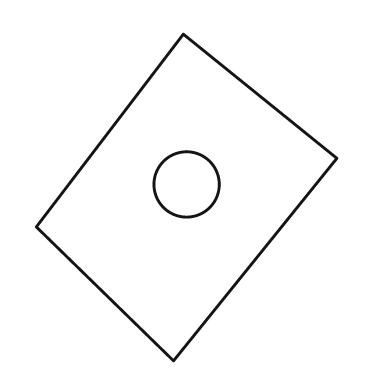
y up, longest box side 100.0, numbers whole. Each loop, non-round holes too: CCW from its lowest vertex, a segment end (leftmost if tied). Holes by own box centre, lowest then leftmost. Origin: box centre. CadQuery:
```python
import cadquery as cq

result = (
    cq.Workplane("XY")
    .moveTo(-4.0, -50.0)
    .lineTo(46.0, 12.0)
    .lineTo(-1.0, 50.0)
    .lineTo(-46.0, -9.0)
    .close()
    .moveTo(0.0, 4.0)
    .circle(10.0)
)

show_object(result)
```